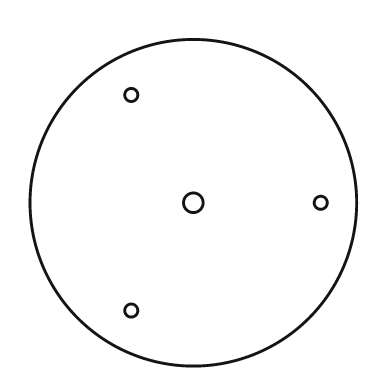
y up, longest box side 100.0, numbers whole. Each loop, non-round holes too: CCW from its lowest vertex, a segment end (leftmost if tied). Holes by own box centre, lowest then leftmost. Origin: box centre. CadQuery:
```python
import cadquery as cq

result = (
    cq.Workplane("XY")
    .moveTo(0.0, 0.0)
    .circle(50.0)
    .moveTo(-19.0, -33.0)
    .circle(2.0)
    .moveTo(0.0, 0.0)
    .circle(3.0)
    .moveTo(39.0, 0.0)
    .circle(2.0)
    .moveTo(-19.0, 33.0)
    .circle(2.0)
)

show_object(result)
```